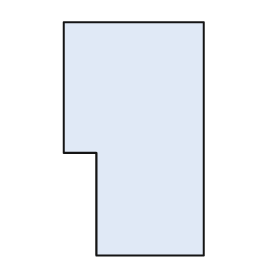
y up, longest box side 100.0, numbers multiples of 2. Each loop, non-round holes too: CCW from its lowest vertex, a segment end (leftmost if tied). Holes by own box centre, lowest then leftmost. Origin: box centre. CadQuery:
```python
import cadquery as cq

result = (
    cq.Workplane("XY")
    .moveTo(-16.0, -50.0)
    .lineTo(30.0, -50.0)
    .lineTo(30.0, 50.0)
    .lineTo(-30.0, 50.0)
    .lineTo(-30.0, -6.0)
    .lineTo(-16.0, -6.0)
    .close()
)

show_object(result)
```